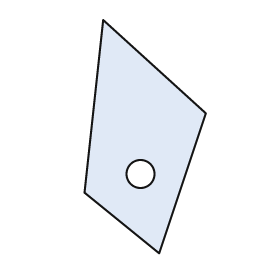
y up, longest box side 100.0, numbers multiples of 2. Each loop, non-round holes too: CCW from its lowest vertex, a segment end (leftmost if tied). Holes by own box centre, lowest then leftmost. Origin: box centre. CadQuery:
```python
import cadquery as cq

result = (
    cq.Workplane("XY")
    .moveTo(6.0, -50.0)
    .lineTo(26.0, 10.0)
    .lineTo(-18.0, 50.0)
    .lineTo(-26.0, -24.0)
    .close()
    .moveTo(-2.0, -16.0)
    .circle(6.0)
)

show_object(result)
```